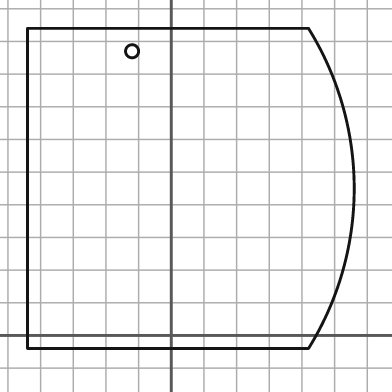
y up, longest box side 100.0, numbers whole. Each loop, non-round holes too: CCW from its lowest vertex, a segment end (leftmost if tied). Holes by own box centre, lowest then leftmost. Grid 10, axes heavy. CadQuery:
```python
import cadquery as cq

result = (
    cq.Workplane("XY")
    .moveTo(-44.0, -4.0)
    .lineTo(42.0, -4.0)
    .threePointArc((56.0, 45.0), (42.0, 94.0))
    .lineTo(-44.0, 94.0)
    .close()
    .moveTo(-12.0, 87.0)
    .circle(2.0)
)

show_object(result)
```